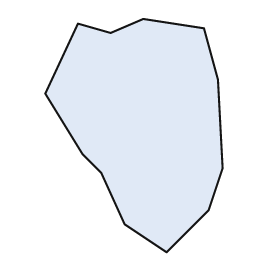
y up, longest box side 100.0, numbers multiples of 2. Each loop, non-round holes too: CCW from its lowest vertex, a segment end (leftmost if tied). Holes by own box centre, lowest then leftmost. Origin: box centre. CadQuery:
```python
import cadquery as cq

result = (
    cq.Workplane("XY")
    .moveTo(14.0, -50.0)
    .lineTo(32.0, -32.0)
    .lineTo(38.0, -14.0)
    .lineTo(36.0, 24.0)
    .lineTo(30.0, 46.0)
    .lineTo(4.0, 50.0)
    .lineTo(-10.0, 44.0)
    .lineTo(-24.0, 48.0)
    .lineTo(-38.0, 18.0)
    .lineTo(-22.0, -8.0)
    .lineTo(-14.0, -16.0)
    .lineTo(-4.0, -38.0)
    .close()
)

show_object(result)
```